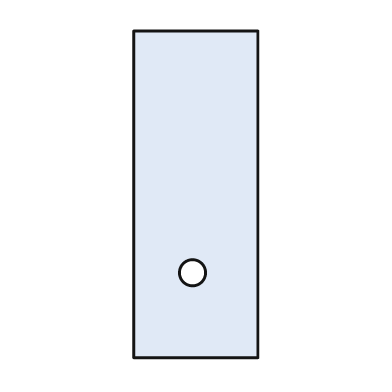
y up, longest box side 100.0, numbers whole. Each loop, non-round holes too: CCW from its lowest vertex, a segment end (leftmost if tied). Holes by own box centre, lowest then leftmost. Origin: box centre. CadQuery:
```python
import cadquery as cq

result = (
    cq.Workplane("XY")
    .moveTo(-19.0, -50.0)
    .lineTo(19.0, -50.0)
    .lineTo(19.0, 50.0)
    .lineTo(-19.0, 50.0)
    .close()
    .moveTo(-1.0, -24.0)
    .circle(4.0)
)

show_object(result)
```